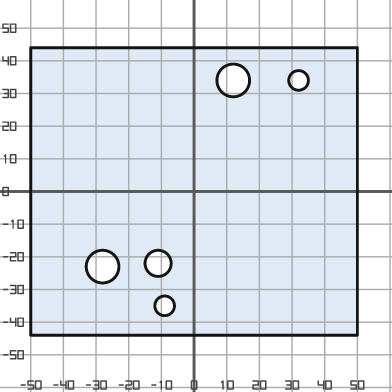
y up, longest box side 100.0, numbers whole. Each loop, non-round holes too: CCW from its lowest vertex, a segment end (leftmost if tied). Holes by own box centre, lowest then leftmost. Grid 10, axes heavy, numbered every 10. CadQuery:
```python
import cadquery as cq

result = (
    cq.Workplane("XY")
    .moveTo(-50.0, -44.0)
    .lineTo(50.0, -44.0)
    .lineTo(50.0, 44.0)
    .lineTo(-50.0, 44.0)
    .close()
    .moveTo(-9.0, -35.0)
    .circle(3.0)
    .moveTo(-28.0, -23.0)
    .circle(5.0)
    .moveTo(-11.0, -22.0)
    .circle(4.0)
    .moveTo(12.0, 34.0)
    .circle(5.0)
    .moveTo(32.0, 34.0)
    .circle(3.0)
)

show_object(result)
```